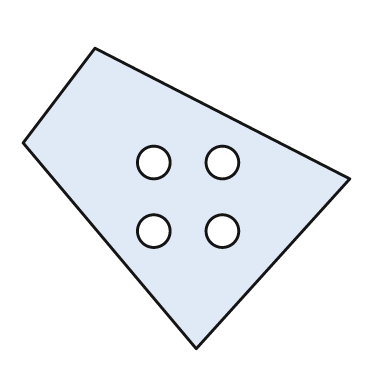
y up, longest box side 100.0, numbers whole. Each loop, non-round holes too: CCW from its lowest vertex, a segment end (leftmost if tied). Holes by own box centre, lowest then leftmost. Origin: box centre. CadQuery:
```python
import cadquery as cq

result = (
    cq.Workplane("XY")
    .moveTo(3.0, -46.0)
    .lineTo(50.0, 6.0)
    .lineTo(-28.0, 46.0)
    .lineTo(-50.0, 17.0)
    .close()
    .moveTo(-10.0, -10.0)
    .circle(5.0)
    .moveTo(11.0, -10.0)
    .circle(5.0)
    .moveTo(-10.0, 11.0)
    .circle(5.0)
    .moveTo(11.0, 11.0)
    .circle(5.0)
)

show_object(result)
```